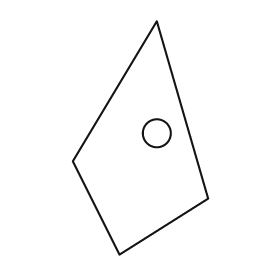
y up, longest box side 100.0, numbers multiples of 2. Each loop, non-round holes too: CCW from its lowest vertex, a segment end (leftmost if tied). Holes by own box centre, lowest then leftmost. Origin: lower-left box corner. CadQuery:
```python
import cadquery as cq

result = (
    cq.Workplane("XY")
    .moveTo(20.0, 0.0)
    .lineTo(58.0, 24.0)
    .lineTo(36.0, 100.0)
    .lineTo(0.0, 40.0)
    .close()
    .moveTo(36.0, 52.0)
    .circle(6.0)
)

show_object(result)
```